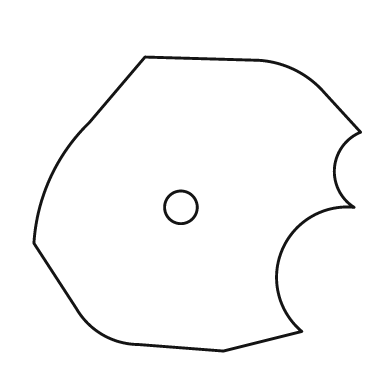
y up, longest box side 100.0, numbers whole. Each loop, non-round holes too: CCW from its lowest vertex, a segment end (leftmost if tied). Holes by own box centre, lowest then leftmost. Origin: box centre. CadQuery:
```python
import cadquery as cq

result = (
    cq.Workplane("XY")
    .moveTo(8.0, -45.0)
    .lineTo(32.0, -39.0)
    .threePointArc((26.0, -14.0), (48.0, -1.0))
    .threePointArc((42.0, 11.0), (50.0, 22.0))
    .lineTo(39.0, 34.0)
    .threePointArc((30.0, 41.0), (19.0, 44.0))
    .lineTo(-16.0, 45.0)
    .lineTo(-33.0, 25.0)
    .threePointArc((-45.0, 8.0), (-50.0, -12.0))
    .lineTo(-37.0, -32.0)
    .threePointArc((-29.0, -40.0), (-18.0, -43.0))
    .close()
    .moveTo(-5.0, -1.0)
    .circle(5.0)
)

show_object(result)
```